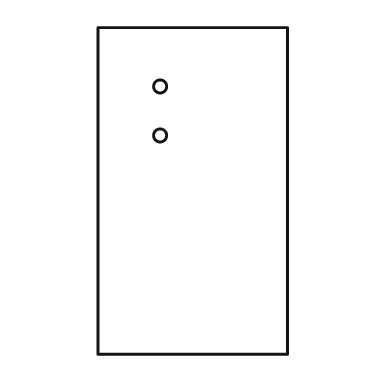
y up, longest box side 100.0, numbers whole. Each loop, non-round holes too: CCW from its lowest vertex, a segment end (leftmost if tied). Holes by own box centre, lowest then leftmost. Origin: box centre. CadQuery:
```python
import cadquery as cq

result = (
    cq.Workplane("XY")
    .moveTo(-29.0, -50.0)
    .lineTo(29.0, -50.0)
    .lineTo(29.0, 50.0)
    .lineTo(-29.0, 50.0)
    .close()
    .moveTo(-10.0, 17.0)
    .circle(2.0)
    .moveTo(-10.0, 32.0)
    .circle(2.0)
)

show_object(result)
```